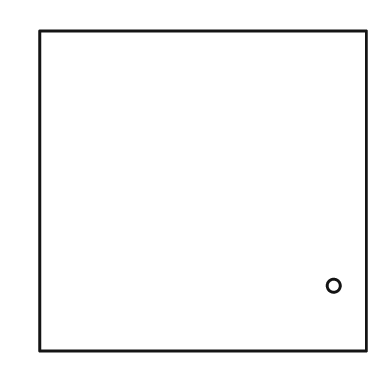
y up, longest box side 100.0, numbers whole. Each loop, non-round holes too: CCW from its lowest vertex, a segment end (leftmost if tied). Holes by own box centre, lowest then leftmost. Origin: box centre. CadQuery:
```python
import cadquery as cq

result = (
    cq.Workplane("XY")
    .moveTo(-50.0, -49.0)
    .lineTo(50.0, -49.0)
    .lineTo(50.0, 49.0)
    .lineTo(-50.0, 49.0)
    .close()
    .moveTo(40.0, -29.0)
    .circle(2.0)
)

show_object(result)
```